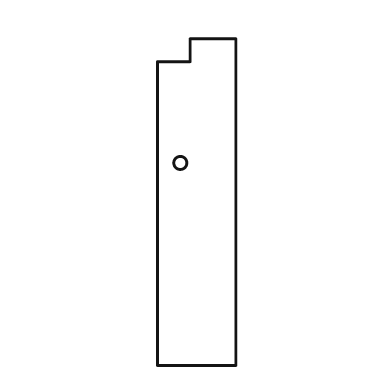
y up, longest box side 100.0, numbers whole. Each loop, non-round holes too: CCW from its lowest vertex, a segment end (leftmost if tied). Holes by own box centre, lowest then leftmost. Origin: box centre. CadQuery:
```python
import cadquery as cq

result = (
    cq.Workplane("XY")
    .moveTo(-12.0, -50.0)
    .lineTo(12.0, -50.0)
    .lineTo(12.0, 50.0)
    .lineTo(-2.0, 50.0)
    .lineTo(-2.0, 43.0)
    .lineTo(-12.0, 43.0)
    .close()
    .moveTo(-5.0, 12.0)
    .circle(2.0)
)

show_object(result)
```